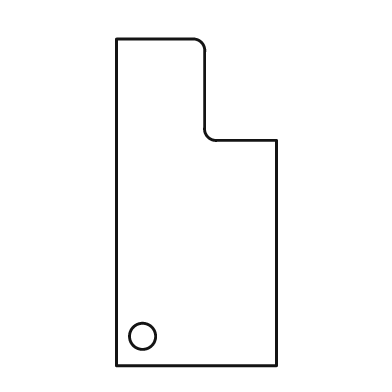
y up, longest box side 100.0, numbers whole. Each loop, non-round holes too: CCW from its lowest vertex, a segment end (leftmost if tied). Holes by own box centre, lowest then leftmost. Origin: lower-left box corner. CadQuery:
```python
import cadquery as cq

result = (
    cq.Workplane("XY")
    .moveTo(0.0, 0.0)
    .lineTo(49.0, 0.0)
    .lineTo(49.0, 69.0)
    .lineTo(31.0, 69.0)
    .threePointArc((28.0, 70.0), (27.0, 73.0))
    .lineTo(27.0, 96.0)
    .threePointArc((26.0, 99.0), (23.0, 100.0))
    .lineTo(0.0, 100.0)
    .close()
    .moveTo(8.0, 9.0)
    .circle(4.0)
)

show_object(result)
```